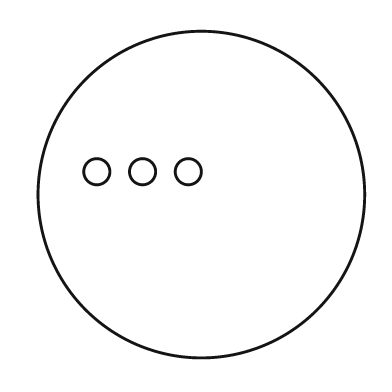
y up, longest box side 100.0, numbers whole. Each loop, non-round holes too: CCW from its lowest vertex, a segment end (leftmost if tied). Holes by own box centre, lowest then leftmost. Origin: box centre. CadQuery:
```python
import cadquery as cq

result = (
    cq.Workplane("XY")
    .moveTo(0.0, 0.0)
    .circle(50.0)
    .moveTo(-32.0, 7.0)
    .circle(4.0)
    .moveTo(-18.0, 7.0)
    .circle(4.0)
    .moveTo(-4.0, 7.0)
    .circle(4.0)
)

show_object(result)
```